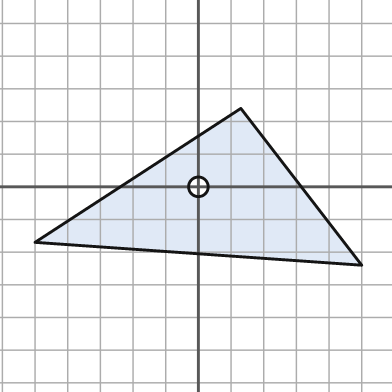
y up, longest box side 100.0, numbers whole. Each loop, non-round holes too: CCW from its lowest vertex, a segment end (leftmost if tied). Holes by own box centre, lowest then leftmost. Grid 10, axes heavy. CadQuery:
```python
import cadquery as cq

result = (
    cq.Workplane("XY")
    .moveTo(50.0, -24.0)
    .lineTo(13.0, 24.0)
    .lineTo(-50.0, -17.0)
    .close()
    .moveTo(0.0, 0.0)
    .circle(3.0)
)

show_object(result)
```